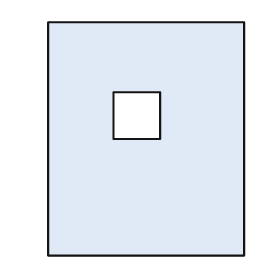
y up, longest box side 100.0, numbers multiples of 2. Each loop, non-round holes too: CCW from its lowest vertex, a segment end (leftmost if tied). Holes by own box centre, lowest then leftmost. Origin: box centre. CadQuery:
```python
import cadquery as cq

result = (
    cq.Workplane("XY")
    .moveTo(-42.0, -50.0)
    .lineTo(42.0, -50.0)
    .lineTo(42.0, 50.0)
    .lineTo(-42.0, 50.0)
    .close()
    .moveTo(-14.0, 0.0)
    .lineTo(6.0, 0.0)
    .lineTo(6.0, 20.0)
    .lineTo(-14.0, 20.0)
    .close()
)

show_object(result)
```